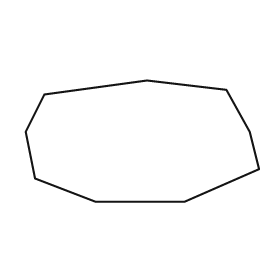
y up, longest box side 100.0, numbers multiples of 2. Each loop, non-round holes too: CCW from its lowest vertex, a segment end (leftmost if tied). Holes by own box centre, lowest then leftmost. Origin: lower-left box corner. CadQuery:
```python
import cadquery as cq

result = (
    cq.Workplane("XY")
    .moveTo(30.0, 0.0)
    .lineTo(68.0, 0.0)
    .lineTo(100.0, 14.0)
    .lineTo(96.0, 30.0)
    .lineTo(86.0, 48.0)
    .lineTo(52.0, 52.0)
    .lineTo(8.0, 46.0)
    .lineTo(0.0, 30.0)
    .lineTo(4.0, 10.0)
    .close()
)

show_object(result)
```